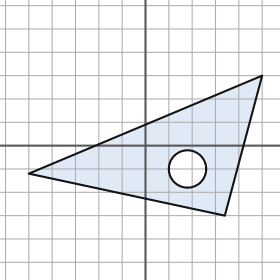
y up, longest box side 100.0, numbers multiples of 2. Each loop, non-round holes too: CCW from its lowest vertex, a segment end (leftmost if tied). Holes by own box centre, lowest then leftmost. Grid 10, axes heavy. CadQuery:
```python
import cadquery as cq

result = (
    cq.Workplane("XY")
    .moveTo(34.0, -30.0)
    .lineTo(50.0, 30.0)
    .lineTo(-50.0, -12.0)
    .close()
    .moveTo(18.0, -10.0)
    .circle(8.0)
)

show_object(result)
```